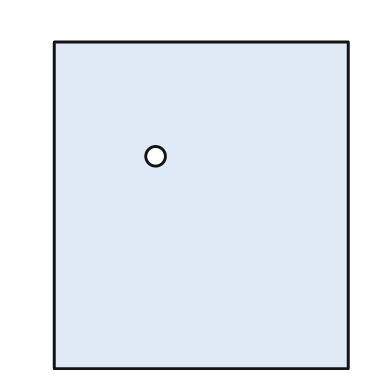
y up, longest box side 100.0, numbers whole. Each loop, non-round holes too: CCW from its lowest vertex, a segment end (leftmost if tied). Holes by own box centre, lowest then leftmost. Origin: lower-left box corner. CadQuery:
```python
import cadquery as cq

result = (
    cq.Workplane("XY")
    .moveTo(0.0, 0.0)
    .lineTo(90.0, 0.0)
    .lineTo(90.0, 100.0)
    .lineTo(0.0, 100.0)
    .close()
    .moveTo(31.0, 65.0)
    .circle(3.0)
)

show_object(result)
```